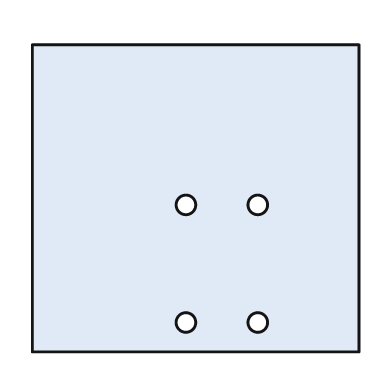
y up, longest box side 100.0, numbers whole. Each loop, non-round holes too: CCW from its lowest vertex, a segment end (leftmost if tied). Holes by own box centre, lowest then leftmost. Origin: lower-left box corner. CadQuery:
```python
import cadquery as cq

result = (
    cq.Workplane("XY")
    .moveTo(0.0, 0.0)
    .lineTo(100.0, 0.0)
    .lineTo(100.0, 94.0)
    .lineTo(0.0, 94.0)
    .close()
    .moveTo(47.0, 9.0)
    .circle(3.0)
    .moveTo(69.0, 9.0)
    .circle(3.0)
    .moveTo(47.0, 45.0)
    .circle(3.0)
    .moveTo(69.0, 45.0)
    .circle(3.0)
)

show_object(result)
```